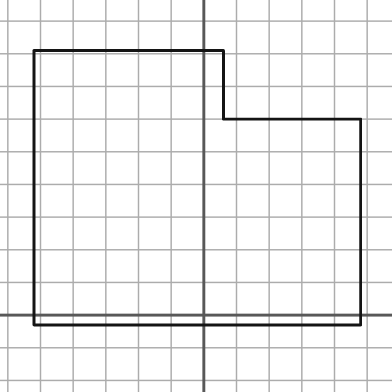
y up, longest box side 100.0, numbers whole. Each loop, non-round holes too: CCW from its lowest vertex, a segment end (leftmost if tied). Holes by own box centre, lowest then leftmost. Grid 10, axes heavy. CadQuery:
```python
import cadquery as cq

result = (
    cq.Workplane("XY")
    .moveTo(-52.0, -3.0)
    .lineTo(48.0, -3.0)
    .lineTo(48.0, 60.0)
    .lineTo(6.0, 60.0)
    .lineTo(6.0, 81.0)
    .lineTo(-52.0, 81.0)
    .close()
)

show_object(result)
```